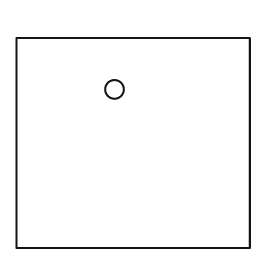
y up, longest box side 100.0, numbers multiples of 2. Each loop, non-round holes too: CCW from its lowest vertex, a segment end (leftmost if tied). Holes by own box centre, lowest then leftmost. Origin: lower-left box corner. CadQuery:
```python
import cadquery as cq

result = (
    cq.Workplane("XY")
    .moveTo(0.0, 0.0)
    .lineTo(100.0, 0.0)
    .lineTo(100.0, 90.0)
    .lineTo(0.0, 90.0)
    .close()
    .moveTo(42.0, 68.0)
    .circle(4.0)
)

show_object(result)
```